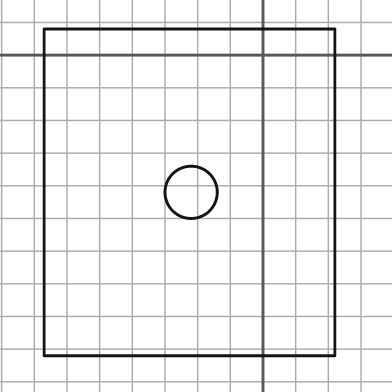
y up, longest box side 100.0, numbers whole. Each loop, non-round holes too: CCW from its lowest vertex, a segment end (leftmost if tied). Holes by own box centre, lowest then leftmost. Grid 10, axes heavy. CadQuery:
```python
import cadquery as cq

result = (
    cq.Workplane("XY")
    .moveTo(-67.0, -92.0)
    .lineTo(22.0, -92.0)
    .lineTo(22.0, 8.0)
    .lineTo(-67.0, 8.0)
    .close()
    .moveTo(-22.0, -42.0)
    .circle(8.0)
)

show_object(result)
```